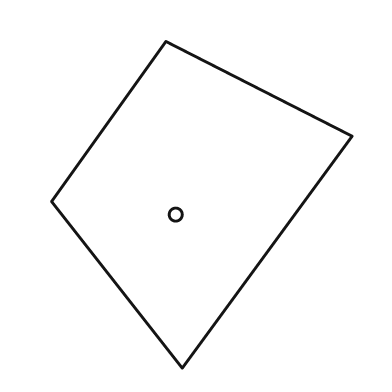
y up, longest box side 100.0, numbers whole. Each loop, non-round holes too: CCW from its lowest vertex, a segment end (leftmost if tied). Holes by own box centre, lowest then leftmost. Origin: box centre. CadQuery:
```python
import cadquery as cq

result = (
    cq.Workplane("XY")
    .moveTo(-6.0, -50.0)
    .lineTo(46.0, 21.0)
    .lineTo(-11.0, 50.0)
    .lineTo(-46.0, 1.0)
    .close()
    .moveTo(-8.0, -3.0)
    .circle(2.0)
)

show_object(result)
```